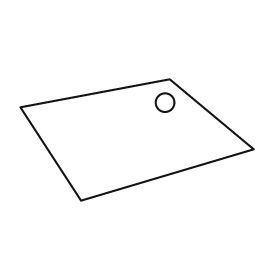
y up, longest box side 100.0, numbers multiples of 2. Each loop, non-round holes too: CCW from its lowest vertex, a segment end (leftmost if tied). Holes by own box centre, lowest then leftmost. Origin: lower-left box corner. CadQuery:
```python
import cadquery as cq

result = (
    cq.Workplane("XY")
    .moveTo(26.0, 0.0)
    .lineTo(100.0, 22.0)
    .lineTo(64.0, 52.0)
    .lineTo(0.0, 40.0)
    .close()
    .moveTo(62.0, 42.0)
    .circle(4.0)
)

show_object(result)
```